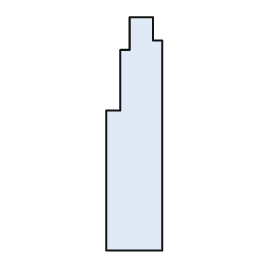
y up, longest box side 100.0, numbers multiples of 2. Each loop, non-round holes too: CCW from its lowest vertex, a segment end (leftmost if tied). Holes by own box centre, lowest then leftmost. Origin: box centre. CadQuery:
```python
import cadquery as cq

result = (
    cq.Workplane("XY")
    .moveTo(-12.0, -50.0)
    .lineTo(12.0, -50.0)
    .lineTo(12.0, 40.0)
    .lineTo(8.0, 40.0)
    .lineTo(8.0, 50.0)
    .lineTo(-2.0, 50.0)
    .lineTo(-2.0, 36.0)
    .lineTo(-6.0, 36.0)
    .lineTo(-6.0, 10.0)
    .lineTo(-12.0, 10.0)
    .close()
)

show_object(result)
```